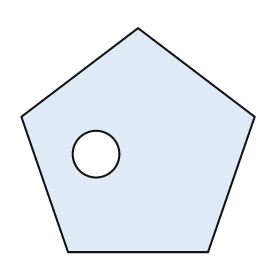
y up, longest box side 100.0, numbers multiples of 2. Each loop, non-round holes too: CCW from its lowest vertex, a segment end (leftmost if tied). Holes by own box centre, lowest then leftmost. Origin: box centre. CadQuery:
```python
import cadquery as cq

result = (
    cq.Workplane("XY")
    .moveTo(-30.0, -48.0)
    .lineTo(30.0, -48.0)
    .lineTo(50.0, 10.0)
    .lineTo(0.0, 48.0)
    .lineTo(-50.0, 10.0)
    .close()
    .moveTo(-18.0, -6.0)
    .circle(10.0)
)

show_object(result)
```